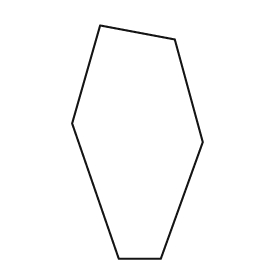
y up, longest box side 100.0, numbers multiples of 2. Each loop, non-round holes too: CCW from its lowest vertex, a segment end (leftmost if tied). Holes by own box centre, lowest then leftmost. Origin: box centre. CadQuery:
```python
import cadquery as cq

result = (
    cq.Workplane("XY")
    .moveTo(-8.0, -50.0)
    .lineTo(10.0, -50.0)
    .lineTo(28.0, 0.0)
    .lineTo(16.0, 44.0)
    .lineTo(-16.0, 50.0)
    .lineTo(-28.0, 8.0)
    .close()
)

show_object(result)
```